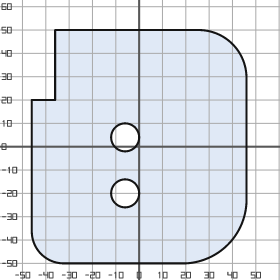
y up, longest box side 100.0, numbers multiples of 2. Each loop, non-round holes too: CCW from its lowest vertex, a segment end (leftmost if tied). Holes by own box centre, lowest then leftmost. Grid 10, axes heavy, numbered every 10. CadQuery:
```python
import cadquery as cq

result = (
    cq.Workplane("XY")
    .moveTo(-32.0, -50.0)
    .lineTo(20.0, -50.0)
    .threePointArc((38.0, -42.0), (46.0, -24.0))
    .lineTo(46.0, 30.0)
    .threePointArc((40.0, 44.0), (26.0, 50.0))
    .lineTo(-36.0, 50.0)
    .lineTo(-36.0, 20.0)
    .lineTo(-46.0, 20.0)
    .lineTo(-46.0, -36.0)
    .threePointArc((-42.0, -46.0), (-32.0, -50.0))
    .close()
    .moveTo(-6.0, -20.0)
    .circle(6.0)
    .moveTo(-6.0, 4.0)
    .circle(6.0)
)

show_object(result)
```